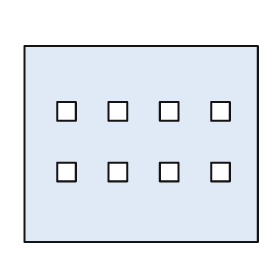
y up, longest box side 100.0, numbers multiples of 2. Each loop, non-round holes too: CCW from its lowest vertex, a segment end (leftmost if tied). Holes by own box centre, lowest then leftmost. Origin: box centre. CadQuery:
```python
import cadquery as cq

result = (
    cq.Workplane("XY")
    .moveTo(-50.0, -42.0)
    .lineTo(50.0, -42.0)
    .lineTo(50.0, 42.0)
    .lineTo(-50.0, 42.0)
    .close()
    .moveTo(-36.0, -16.0)
    .lineTo(-28.0, -16.0)
    .lineTo(-28.0, -8.0)
    .lineTo(-36.0, -8.0)
    .close()
    .moveTo(-14.0, -16.0)
    .lineTo(-6.0, -16.0)
    .lineTo(-6.0, -8.0)
    .lineTo(-14.0, -8.0)
    .close()
    .moveTo(8.0, -16.0)
    .lineTo(16.0, -16.0)
    .lineTo(16.0, -8.0)
    .lineTo(8.0, -8.0)
    .close()
    .moveTo(30.0, -16.0)
    .lineTo(38.0, -16.0)
    .lineTo(38.0, -8.0)
    .lineTo(30.0, -8.0)
    .close()
    .moveTo(-36.0, 10.0)
    .lineTo(-28.0, 10.0)
    .lineTo(-28.0, 18.0)
    .lineTo(-36.0, 18.0)
    .close()
    .moveTo(-14.0, 10.0)
    .lineTo(-6.0, 10.0)
    .lineTo(-6.0, 18.0)
    .lineTo(-14.0, 18.0)
    .close()
    .moveTo(8.0, 10.0)
    .lineTo(16.0, 10.0)
    .lineTo(16.0, 18.0)
    .lineTo(8.0, 18.0)
    .close()
    .moveTo(30.0, 10.0)
    .lineTo(38.0, 10.0)
    .lineTo(38.0, 18.0)
    .lineTo(30.0, 18.0)
    .close()
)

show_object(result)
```